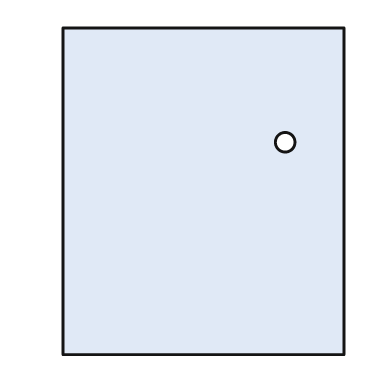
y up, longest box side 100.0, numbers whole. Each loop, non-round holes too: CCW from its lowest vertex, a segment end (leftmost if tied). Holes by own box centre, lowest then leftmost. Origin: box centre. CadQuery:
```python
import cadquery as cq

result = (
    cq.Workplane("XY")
    .moveTo(-43.0, -50.0)
    .lineTo(43.0, -50.0)
    .lineTo(43.0, 50.0)
    .lineTo(-43.0, 50.0)
    .close()
    .moveTo(25.0, 15.0)
    .circle(3.0)
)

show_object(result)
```